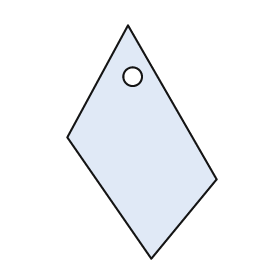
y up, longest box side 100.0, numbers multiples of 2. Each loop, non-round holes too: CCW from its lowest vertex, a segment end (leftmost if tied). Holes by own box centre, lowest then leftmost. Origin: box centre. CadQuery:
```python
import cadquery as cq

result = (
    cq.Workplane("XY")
    .moveTo(4.0, -50.0)
    .lineTo(32.0, -16.0)
    .lineTo(-6.0, 50.0)
    .lineTo(-32.0, 2.0)
    .close()
    .moveTo(-4.0, 28.0)
    .circle(4.0)
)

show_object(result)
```